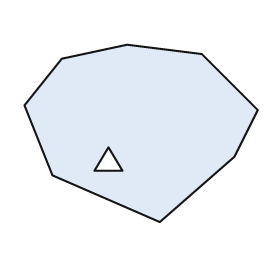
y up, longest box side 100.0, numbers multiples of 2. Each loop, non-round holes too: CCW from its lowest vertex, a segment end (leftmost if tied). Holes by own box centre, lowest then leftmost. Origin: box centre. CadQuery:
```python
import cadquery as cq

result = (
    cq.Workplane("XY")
    .moveTo(8.0, -38.0)
    .lineTo(40.0, -10.0)
    .lineTo(50.0, 10.0)
    .lineTo(26.0, 34.0)
    .lineTo(-6.0, 38.0)
    .lineTo(-34.0, 32.0)
    .lineTo(-50.0, 12.0)
    .lineTo(-38.0, -18.0)
    .close()
    .moveTo(-20.0, -16.0)
    .lineTo(-8.0, -16.0)
    .lineTo(-14.0, -6.0)
    .close()
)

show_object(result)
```